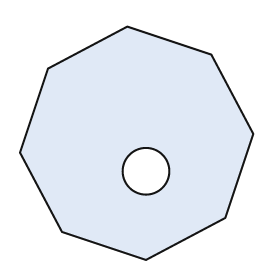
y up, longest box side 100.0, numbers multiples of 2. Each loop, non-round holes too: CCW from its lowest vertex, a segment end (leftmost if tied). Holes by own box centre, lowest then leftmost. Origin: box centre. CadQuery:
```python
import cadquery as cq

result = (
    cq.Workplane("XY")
    .moveTo(4.0, -50.0)
    .lineTo(38.0, -32.0)
    .lineTo(50.0, 4.0)
    .lineTo(32.0, 38.0)
    .lineTo(-4.0, 50.0)
    .lineTo(-38.0, 32.0)
    .lineTo(-50.0, -4.0)
    .lineTo(-32.0, -38.0)
    .close()
    .moveTo(4.0, -12.0)
    .circle(10.0)
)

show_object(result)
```